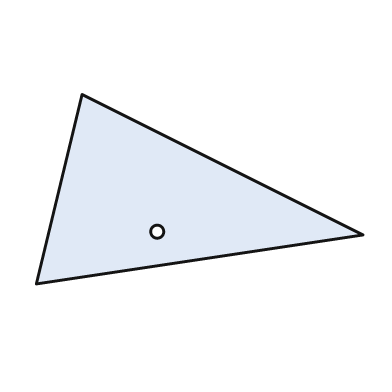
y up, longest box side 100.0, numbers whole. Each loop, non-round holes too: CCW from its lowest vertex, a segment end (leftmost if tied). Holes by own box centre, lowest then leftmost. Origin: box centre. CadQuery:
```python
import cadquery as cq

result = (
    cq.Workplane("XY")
    .moveTo(-50.0, -29.0)
    .lineTo(50.0, -14.0)
    .lineTo(-36.0, 29.0)
    .close()
    .moveTo(-13.0, -13.0)
    .circle(2.0)
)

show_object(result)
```